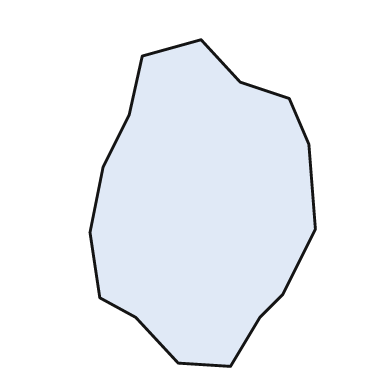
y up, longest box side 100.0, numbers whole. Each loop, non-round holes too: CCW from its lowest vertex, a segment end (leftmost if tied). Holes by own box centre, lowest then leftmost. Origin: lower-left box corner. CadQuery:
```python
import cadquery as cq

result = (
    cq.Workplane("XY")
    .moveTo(43.0, 0.0)
    .lineTo(52.0, 15.0)
    .lineTo(59.0, 22.0)
    .lineTo(69.0, 42.0)
    .lineTo(67.0, 68.0)
    .lineTo(61.0, 82.0)
    .lineTo(46.0, 87.0)
    .lineTo(34.0, 100.0)
    .lineTo(16.0, 95.0)
    .lineTo(12.0, 77.0)
    .lineTo(4.0, 61.0)
    .lineTo(0.0, 41.0)
    .lineTo(3.0, 21.0)
    .lineTo(14.0, 15.0)
    .lineTo(27.0, 1.0)
    .close()
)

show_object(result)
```